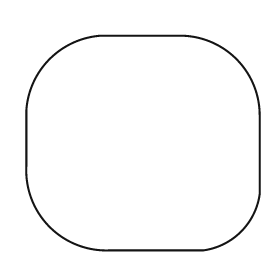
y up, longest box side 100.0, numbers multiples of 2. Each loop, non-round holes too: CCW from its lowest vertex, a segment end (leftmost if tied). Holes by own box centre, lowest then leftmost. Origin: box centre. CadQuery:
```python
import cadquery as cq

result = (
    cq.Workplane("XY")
    .moveTo(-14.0, -46.0)
    .lineTo(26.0, -46.0)
    .threePointArc((42.0, -38.0), (50.0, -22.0))
    .lineTo(50.0, 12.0)
    .threePointArc((40.0, 36.0), (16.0, 46.0))
    .lineTo(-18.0, 46.0)
    .threePointArc((-40.0, 36.0), (-50.0, 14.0))
    .lineTo(-50.0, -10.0)
    .threePointArc((-40.0, -36.0), (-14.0, -46.0))
    .close()
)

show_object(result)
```